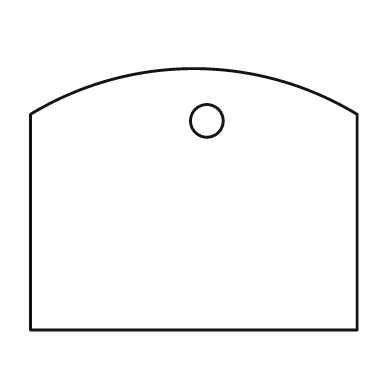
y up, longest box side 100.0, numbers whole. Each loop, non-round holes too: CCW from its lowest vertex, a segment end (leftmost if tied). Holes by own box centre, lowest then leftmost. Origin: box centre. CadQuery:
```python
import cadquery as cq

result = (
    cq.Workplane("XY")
    .moveTo(-50.0, -40.0)
    .lineTo(50.0, -40.0)
    .lineTo(50.0, 26.0)
    .threePointArc((0.0, 40.0), (-50.0, 26.0))
    .close()
    .moveTo(4.0, 24.0)
    .circle(5.0)
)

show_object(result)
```